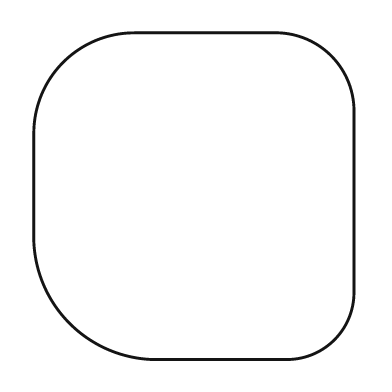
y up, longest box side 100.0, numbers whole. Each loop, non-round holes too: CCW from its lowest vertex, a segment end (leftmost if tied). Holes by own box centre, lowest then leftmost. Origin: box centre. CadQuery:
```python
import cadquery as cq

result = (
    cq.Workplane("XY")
    .moveTo(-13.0, -50.0)
    .lineTo(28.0, -50.0)
    .threePointArc((43.0, -44.0), (49.0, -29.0))
    .lineTo(49.0, 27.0)
    .threePointArc((42.0, 43.0), (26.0, 50.0))
    .lineTo(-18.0, 50.0)
    .threePointArc((-40.0, 41.0), (-49.0, 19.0))
    .lineTo(-49.0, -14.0)
    .threePointArc((-38.0, -39.0), (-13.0, -50.0))
    .close()
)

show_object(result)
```